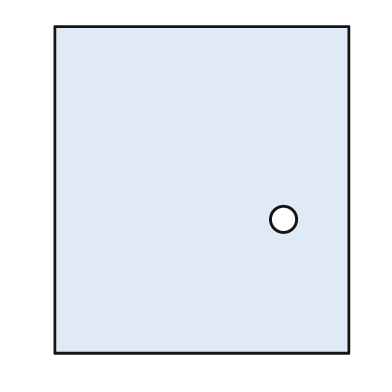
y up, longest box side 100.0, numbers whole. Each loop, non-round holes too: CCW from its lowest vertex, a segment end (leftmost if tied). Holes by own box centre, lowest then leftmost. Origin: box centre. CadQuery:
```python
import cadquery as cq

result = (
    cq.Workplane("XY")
    .moveTo(-45.0, -50.0)
    .lineTo(45.0, -50.0)
    .lineTo(45.0, 50.0)
    .lineTo(-45.0, 50.0)
    .close()
    .moveTo(25.0, -9.0)
    .circle(4.0)
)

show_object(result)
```